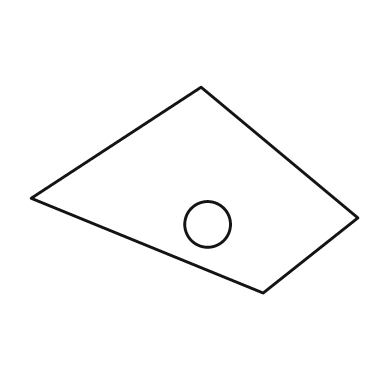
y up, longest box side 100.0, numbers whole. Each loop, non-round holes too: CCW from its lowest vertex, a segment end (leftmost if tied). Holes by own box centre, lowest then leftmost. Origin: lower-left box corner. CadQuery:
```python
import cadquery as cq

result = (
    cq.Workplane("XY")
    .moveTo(71.0, 0.0)
    .lineTo(100.0, 23.0)
    .lineTo(52.0, 63.0)
    .lineTo(0.0, 29.0)
    .close()
    .moveTo(54.0, 21.0)
    .circle(7.0)
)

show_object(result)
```